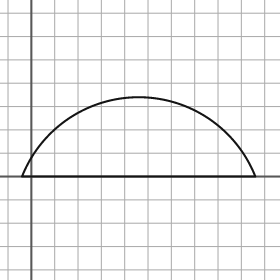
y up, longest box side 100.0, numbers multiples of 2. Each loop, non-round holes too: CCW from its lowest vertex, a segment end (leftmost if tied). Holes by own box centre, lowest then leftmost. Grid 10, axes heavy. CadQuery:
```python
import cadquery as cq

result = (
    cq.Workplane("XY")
    .moveTo(-4.0, 0.0)
    .lineTo(96.0, 0.0)
    .threePointArc((46.0, 34.0), (-4.0, 0.0))
    .close()
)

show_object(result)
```